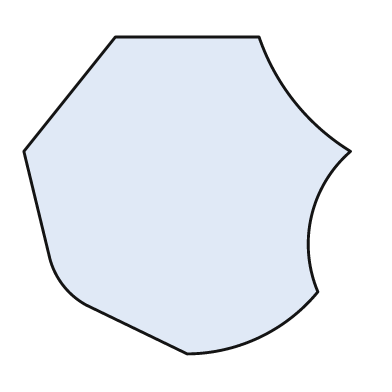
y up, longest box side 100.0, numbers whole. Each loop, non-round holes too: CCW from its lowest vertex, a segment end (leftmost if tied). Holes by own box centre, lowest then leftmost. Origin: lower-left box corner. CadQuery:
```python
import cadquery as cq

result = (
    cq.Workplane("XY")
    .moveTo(50.0, 0.0)
    .threePointArc((72.0, 5.0), (90.0, 19.0))
    .threePointArc((88.0, 42.0), (100.0, 62.0))
    .threePointArc((83.0, 77.0), (72.0, 97.0))
    .lineTo(28.0, 97.0)
    .lineTo(0.0, 62.0)
    .lineTo(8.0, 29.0)
    .threePointArc((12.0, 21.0), (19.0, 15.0))
    .close()
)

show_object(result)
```